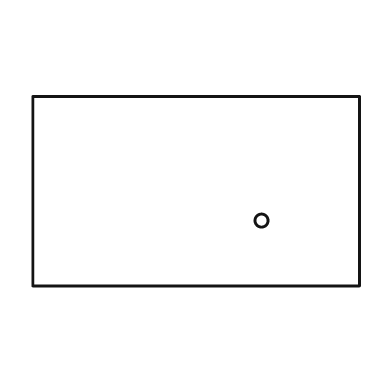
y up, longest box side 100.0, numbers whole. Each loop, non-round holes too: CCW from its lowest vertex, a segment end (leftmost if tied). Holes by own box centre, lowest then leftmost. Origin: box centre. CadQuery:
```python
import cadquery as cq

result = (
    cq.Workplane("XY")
    .moveTo(-50.0, -29.0)
    .lineTo(50.0, -29.0)
    .lineTo(50.0, 29.0)
    .lineTo(-50.0, 29.0)
    .close()
    .moveTo(20.0, -9.0)
    .circle(2.0)
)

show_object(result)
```